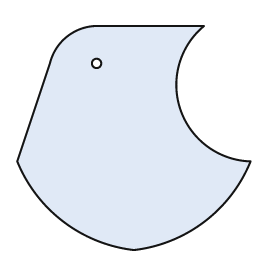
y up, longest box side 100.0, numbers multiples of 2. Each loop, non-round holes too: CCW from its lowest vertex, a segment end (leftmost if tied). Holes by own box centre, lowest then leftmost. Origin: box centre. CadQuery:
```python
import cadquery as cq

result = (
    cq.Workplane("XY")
    .moveTo(0.0, -48.0)
    .threePointArc((30.0, -36.0), (50.0, -10.0))
    .threePointArc((20.0, 12.0), (30.0, 48.0))
    .lineTo(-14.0, 48.0)
    .threePointArc((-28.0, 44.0), (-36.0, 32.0))
    .lineTo(-50.0, -10.0)
    .threePointArc((-30.0, -36.0), (0.0, -48.0))
    .close()
    .moveTo(-16.0, 32.0)
    .circle(2.0)
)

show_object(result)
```